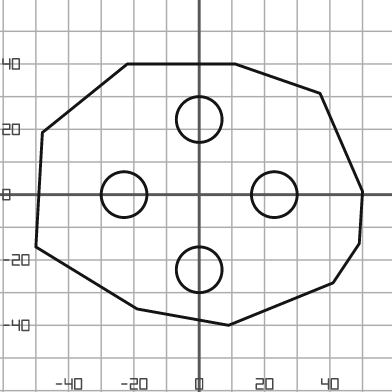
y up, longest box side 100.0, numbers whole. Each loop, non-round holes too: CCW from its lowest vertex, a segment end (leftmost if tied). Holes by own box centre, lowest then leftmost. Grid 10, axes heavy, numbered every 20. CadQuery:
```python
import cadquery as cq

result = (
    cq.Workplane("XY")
    .moveTo(9.0, -40.0)
    .lineTo(41.0, -27.0)
    .lineTo(49.0, -15.0)
    .lineTo(50.0, 1.0)
    .lineTo(37.0, 31.0)
    .lineTo(11.0, 40.0)
    .lineTo(-22.0, 40.0)
    .lineTo(-48.0, 19.0)
    .lineTo(-50.0, -16.0)
    .lineTo(-19.0, -35.0)
    .close()
    .moveTo(0.0, -23.0)
    .circle(7.0)
    .moveTo(-23.0, 0.0)
    .circle(7.0)
    .moveTo(23.0, 0.0)
    .circle(7.0)
    .moveTo(0.0, 23.0)
    .circle(7.0)
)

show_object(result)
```